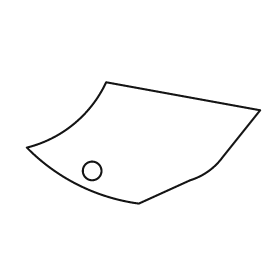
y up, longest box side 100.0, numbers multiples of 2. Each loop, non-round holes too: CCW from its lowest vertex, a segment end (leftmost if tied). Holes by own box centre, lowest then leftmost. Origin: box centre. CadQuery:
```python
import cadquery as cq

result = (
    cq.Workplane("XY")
    .moveTo(-2.0, -26.0)
    .lineTo(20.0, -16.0)
    .threePointArc((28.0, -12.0), (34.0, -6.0))
    .lineTo(50.0, 14.0)
    .lineTo(-16.0, 26.0)
    .threePointArc((-30.0, 8.0), (-50.0, -2.0))
    .threePointArc((-28.0, -18.0), (-2.0, -26.0))
    .close()
    .moveTo(-22.0, -12.0)
    .circle(4.0)
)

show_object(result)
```